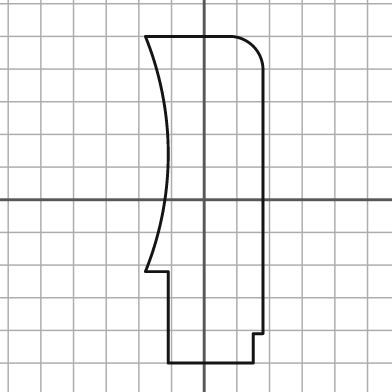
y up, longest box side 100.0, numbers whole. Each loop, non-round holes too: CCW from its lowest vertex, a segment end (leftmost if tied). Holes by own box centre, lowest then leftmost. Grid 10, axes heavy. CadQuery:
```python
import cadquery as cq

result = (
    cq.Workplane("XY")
    .moveTo(-11.0, -50.0)
    .lineTo(15.0, -50.0)
    .lineTo(15.0, -41.0)
    .lineTo(18.0, -41.0)
    .lineTo(18.0, 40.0)
    .threePointArc((15.0, 47.0), (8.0, 50.0))
    .lineTo(-18.0, 50.0)
    .threePointArc((-11.0, 14.0), (-18.0, -22.0))
    .lineTo(-11.0, -22.0)
    .close()
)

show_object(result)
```